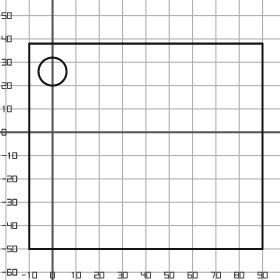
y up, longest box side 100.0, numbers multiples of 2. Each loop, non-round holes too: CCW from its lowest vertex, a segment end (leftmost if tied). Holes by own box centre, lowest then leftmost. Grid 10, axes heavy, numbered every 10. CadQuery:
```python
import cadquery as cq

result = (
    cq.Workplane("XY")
    .moveTo(-10.0, -50.0)
    .lineTo(90.0, -50.0)
    .lineTo(90.0, 38.0)
    .lineTo(-10.0, 38.0)
    .close()
    .moveTo(0.0, 26.0)
    .circle(6.0)
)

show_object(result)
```